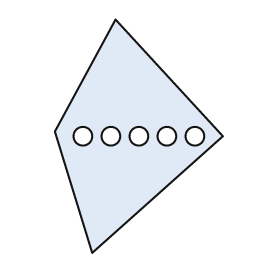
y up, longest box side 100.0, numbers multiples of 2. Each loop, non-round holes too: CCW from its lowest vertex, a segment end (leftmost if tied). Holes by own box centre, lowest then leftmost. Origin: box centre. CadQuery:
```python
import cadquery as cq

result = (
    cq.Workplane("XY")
    .moveTo(-20.0, -50.0)
    .lineTo(36.0, 0.0)
    .lineTo(-10.0, 50.0)
    .lineTo(-36.0, 2.0)
    .close()
    .moveTo(-24.0, 0.0)
    .circle(4.0)
    .moveTo(-12.0, 0.0)
    .circle(4.0)
    .moveTo(0.0, 0.0)
    .circle(4.0)
    .moveTo(12.0, 0.0)
    .circle(4.0)
    .moveTo(24.0, 0.0)
    .circle(4.0)
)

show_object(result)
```